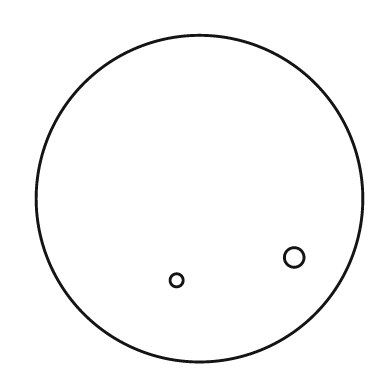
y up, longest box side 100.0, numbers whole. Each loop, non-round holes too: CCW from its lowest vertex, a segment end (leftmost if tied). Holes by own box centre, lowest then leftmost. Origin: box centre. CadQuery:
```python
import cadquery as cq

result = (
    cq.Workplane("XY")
    .moveTo(0.0, 0.0)
    .circle(50.0)
    .moveTo(-7.0, -25.0)
    .circle(2.0)
    .moveTo(29.0, -18.0)
    .circle(3.0)
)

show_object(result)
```